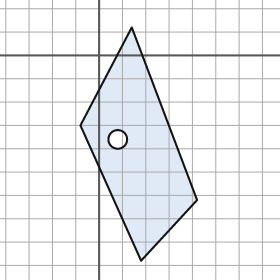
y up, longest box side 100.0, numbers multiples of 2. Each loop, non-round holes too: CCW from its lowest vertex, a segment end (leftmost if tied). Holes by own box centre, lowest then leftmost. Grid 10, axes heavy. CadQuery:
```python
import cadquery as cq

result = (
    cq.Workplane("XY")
    .moveTo(18.0, -88.0)
    .lineTo(42.0, -62.0)
    .lineTo(14.0, 12.0)
    .lineTo(-8.0, -30.0)
    .close()
    .moveTo(8.0, -36.0)
    .circle(4.0)
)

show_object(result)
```